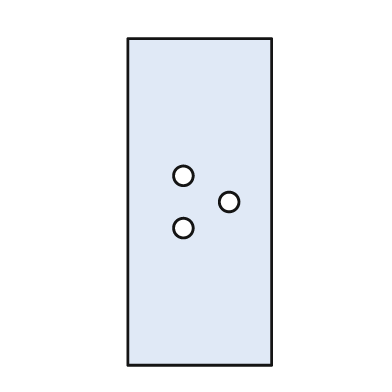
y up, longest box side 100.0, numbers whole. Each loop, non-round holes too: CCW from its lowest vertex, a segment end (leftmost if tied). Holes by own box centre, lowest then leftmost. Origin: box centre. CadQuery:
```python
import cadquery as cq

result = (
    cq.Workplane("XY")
    .moveTo(-22.0, -50.0)
    .lineTo(22.0, -50.0)
    .lineTo(22.0, 50.0)
    .lineTo(-22.0, 50.0)
    .close()
    .moveTo(-5.0, -8.0)
    .circle(3.0)
    .moveTo(9.0, 0.0)
    .circle(3.0)
    .moveTo(-5.0, 8.0)
    .circle(3.0)
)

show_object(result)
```